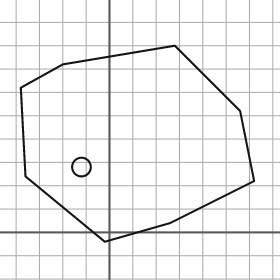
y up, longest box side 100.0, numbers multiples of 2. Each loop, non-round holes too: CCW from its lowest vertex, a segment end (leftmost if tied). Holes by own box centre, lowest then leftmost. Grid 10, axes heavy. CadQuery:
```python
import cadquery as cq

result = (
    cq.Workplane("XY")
    .moveTo(-2.0, -4.0)
    .lineTo(26.0, 4.0)
    .lineTo(62.0, 22.0)
    .lineTo(56.0, 52.0)
    .lineTo(28.0, 80.0)
    .lineTo(-20.0, 72.0)
    .lineTo(-38.0, 62.0)
    .lineTo(-36.0, 24.0)
    .close()
    .moveTo(-12.0, 28.0)
    .circle(4.0)
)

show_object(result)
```